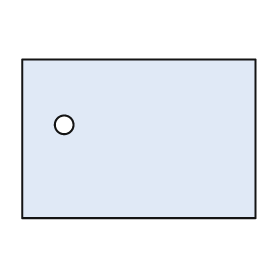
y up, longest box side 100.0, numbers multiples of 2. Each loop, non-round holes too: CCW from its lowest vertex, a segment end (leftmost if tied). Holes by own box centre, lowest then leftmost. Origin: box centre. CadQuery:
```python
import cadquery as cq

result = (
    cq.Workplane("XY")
    .moveTo(-50.0, -34.0)
    .lineTo(50.0, -34.0)
    .lineTo(50.0, 34.0)
    .lineTo(-50.0, 34.0)
    .close()
    .moveTo(-32.0, 6.0)
    .circle(4.0)
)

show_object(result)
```